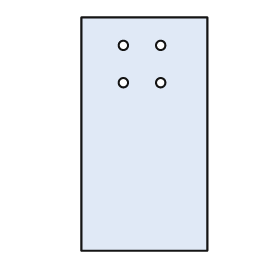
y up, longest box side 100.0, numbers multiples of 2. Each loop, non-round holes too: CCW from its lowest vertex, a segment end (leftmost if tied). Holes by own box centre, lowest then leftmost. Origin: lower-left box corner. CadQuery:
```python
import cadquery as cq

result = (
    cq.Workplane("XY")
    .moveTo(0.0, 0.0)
    .lineTo(54.0, 0.0)
    .lineTo(54.0, 100.0)
    .lineTo(0.0, 100.0)
    .close()
    .moveTo(18.0, 72.0)
    .circle(2.0)
    .moveTo(34.0, 72.0)
    .circle(2.0)
    .moveTo(18.0, 88.0)
    .circle(2.0)
    .moveTo(34.0, 88.0)
    .circle(2.0)
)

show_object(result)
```